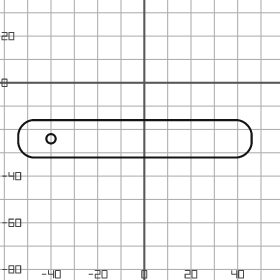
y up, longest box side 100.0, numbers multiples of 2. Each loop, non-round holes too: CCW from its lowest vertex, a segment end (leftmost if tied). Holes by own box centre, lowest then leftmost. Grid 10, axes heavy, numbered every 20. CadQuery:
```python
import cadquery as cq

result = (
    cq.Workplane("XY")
    .moveTo(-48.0, -32.0)
    .lineTo(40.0, -32.0)
    .threePointArc((44.0, -30.0), (46.0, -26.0))
    .lineTo(46.0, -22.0)
    .threePointArc((44.0, -18.0), (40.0, -16.0))
    .lineTo(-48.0, -16.0)
    .threePointArc((-52.0, -18.0), (-54.0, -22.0))
    .lineTo(-54.0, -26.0)
    .threePointArc((-52.0, -30.0), (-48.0, -32.0))
    .close()
    .moveTo(-40.0, -24.0)
    .circle(2.0)
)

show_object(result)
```